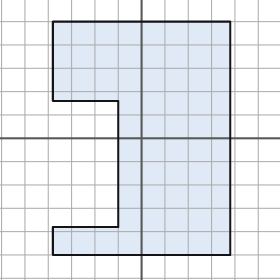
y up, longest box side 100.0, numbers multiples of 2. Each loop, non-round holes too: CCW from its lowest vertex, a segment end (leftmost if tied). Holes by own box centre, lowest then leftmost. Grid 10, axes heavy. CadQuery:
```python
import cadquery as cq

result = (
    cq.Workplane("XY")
    .moveTo(-38.0, -50.0)
    .lineTo(38.0, -50.0)
    .lineTo(38.0, 50.0)
    .lineTo(-38.0, 50.0)
    .lineTo(-38.0, 16.0)
    .lineTo(-10.0, 16.0)
    .lineTo(-10.0, -38.0)
    .lineTo(-38.0, -38.0)
    .close()
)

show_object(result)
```